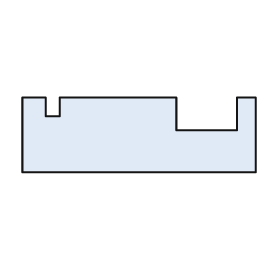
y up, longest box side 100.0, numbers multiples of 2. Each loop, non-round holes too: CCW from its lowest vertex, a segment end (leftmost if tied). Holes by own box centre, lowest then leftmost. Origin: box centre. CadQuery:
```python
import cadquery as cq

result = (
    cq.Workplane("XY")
    .moveTo(-50.0, -16.0)
    .lineTo(50.0, -16.0)
    .lineTo(50.0, 16.0)
    .lineTo(42.0, 16.0)
    .lineTo(42.0, 2.0)
    .lineTo(16.0, 2.0)
    .lineTo(16.0, 16.0)
    .lineTo(-34.0, 16.0)
    .lineTo(-34.0, 8.0)
    .lineTo(-40.0, 8.0)
    .lineTo(-40.0, 16.0)
    .lineTo(-50.0, 16.0)
    .close()
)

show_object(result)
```